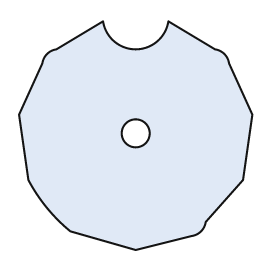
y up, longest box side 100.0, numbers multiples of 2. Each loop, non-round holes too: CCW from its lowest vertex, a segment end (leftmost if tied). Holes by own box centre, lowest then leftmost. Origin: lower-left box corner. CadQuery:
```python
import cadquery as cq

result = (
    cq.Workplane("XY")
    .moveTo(50.0, 0.0)
    .lineTo(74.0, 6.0)
    .threePointArc((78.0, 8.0), (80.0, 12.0))
    .lineTo(96.0, 30.0)
    .lineTo(100.0, 58.0)
    .lineTo(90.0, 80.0)
    .threePointArc((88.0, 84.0), (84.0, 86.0))
    .lineTo(64.0, 98.0)
    .threePointArc((50.0, 86.0), (36.0, 98.0))
    .lineTo(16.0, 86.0)
    .threePointArc((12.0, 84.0), (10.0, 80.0))
    .lineTo(0.0, 58.0)
    .lineTo(4.0, 30.0)
    .threePointArc((12.0, 18.0), (22.0, 8.0))
    .close()
    .moveTo(50.0, 50.0)
    .circle(6.0)
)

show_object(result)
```